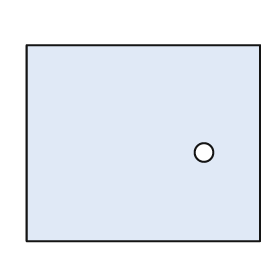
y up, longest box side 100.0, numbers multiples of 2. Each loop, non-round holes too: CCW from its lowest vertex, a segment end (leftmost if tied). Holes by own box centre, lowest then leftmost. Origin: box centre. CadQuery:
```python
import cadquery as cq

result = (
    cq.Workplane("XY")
    .moveTo(-50.0, -42.0)
    .lineTo(50.0, -42.0)
    .lineTo(50.0, 42.0)
    .lineTo(-50.0, 42.0)
    .close()
    .moveTo(26.0, -4.0)
    .circle(4.0)
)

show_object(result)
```